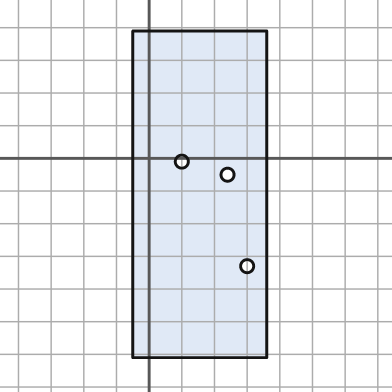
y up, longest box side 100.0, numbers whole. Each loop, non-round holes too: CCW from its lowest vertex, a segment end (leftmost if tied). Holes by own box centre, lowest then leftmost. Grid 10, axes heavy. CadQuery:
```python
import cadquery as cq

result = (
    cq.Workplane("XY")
    .moveTo(-5.0, -61.0)
    .lineTo(36.0, -61.0)
    .lineTo(36.0, 39.0)
    .lineTo(-5.0, 39.0)
    .close()
    .moveTo(30.0, -33.0)
    .circle(2.0)
    .moveTo(24.0, -5.0)
    .circle(2.0)
    .moveTo(10.0, -1.0)
    .circle(2.0)
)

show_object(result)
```